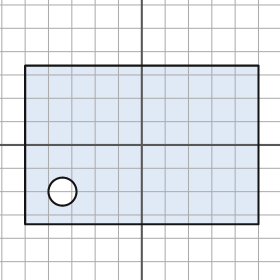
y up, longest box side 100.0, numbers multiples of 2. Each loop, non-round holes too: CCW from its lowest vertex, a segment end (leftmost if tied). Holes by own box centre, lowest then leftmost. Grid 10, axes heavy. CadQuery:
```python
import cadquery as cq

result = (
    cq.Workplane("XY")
    .moveTo(-50.0, -34.0)
    .lineTo(50.0, -34.0)
    .lineTo(50.0, 34.0)
    .lineTo(-50.0, 34.0)
    .close()
    .moveTo(-34.0, -20.0)
    .circle(6.0)
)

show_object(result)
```